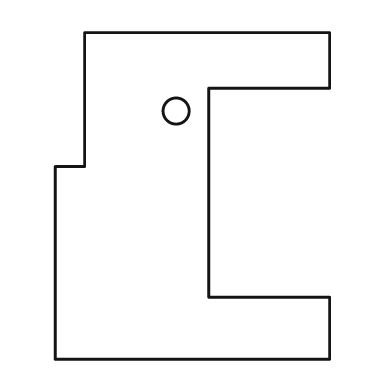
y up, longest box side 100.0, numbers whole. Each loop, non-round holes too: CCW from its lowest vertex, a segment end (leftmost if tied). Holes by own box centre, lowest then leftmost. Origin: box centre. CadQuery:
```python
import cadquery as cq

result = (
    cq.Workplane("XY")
    .moveTo(-42.0, -50.0)
    .lineTo(42.0, -50.0)
    .lineTo(42.0, -31.0)
    .lineTo(5.0, -31.0)
    .lineTo(5.0, 33.0)
    .lineTo(42.0, 33.0)
    .lineTo(42.0, 50.0)
    .lineTo(-33.0, 50.0)
    .lineTo(-33.0, 9.0)
    .lineTo(-42.0, 9.0)
    .close()
    .moveTo(-5.0, 26.0)
    .circle(4.0)
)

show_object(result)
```